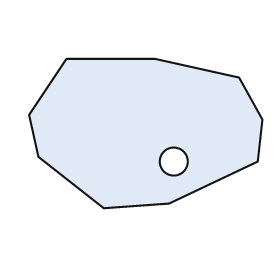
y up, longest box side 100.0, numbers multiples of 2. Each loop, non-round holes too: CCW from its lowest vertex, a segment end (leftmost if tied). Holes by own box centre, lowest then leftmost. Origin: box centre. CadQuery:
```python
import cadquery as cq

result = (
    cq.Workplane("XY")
    .moveTo(-18.0, -32.0)
    .lineTo(10.0, -30.0)
    .lineTo(48.0, -12.0)
    .lineTo(50.0, 6.0)
    .lineTo(40.0, 24.0)
    .lineTo(4.0, 32.0)
    .lineTo(-34.0, 32.0)
    .lineTo(-50.0, 8.0)
    .lineTo(-46.0, -10.0)
    .close()
    .moveTo(12.0, -12.0)
    .circle(6.0)
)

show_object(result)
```